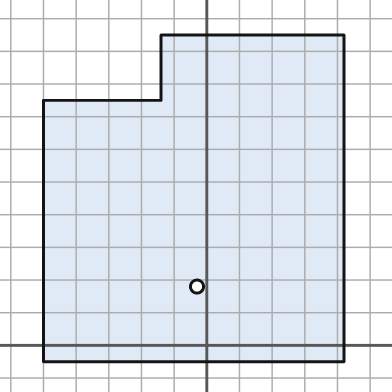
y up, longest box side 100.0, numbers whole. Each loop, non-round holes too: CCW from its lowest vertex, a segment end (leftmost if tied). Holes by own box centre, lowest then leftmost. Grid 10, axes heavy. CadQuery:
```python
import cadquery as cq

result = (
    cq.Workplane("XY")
    .moveTo(-50.0, -5.0)
    .lineTo(42.0, -5.0)
    .lineTo(42.0, 95.0)
    .lineTo(-14.0, 95.0)
    .lineTo(-14.0, 75.0)
    .lineTo(-50.0, 75.0)
    .close()
    .moveTo(-3.0, 18.0)
    .circle(2.0)
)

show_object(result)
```